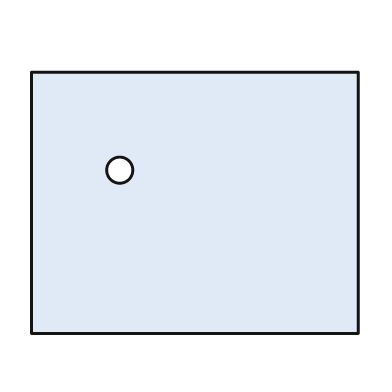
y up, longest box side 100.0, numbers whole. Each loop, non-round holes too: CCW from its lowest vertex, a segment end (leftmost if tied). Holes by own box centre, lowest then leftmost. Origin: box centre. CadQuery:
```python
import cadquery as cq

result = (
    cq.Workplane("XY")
    .moveTo(-50.0, -40.0)
    .lineTo(50.0, -40.0)
    .lineTo(50.0, 40.0)
    .lineTo(-50.0, 40.0)
    .close()
    .moveTo(-23.0, 10.0)
    .circle(4.0)
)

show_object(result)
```